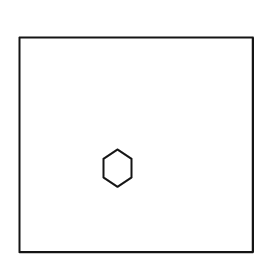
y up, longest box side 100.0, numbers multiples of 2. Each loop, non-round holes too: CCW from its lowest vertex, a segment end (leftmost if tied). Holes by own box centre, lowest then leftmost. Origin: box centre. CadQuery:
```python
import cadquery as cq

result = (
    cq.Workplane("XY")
    .moveTo(-50.0, -46.0)
    .lineTo(50.0, -46.0)
    .lineTo(50.0, 46.0)
    .lineTo(-50.0, 46.0)
    .close()
    .moveTo(-8.0, -18.0)
    .lineTo(-2.0, -14.0)
    .lineTo(-2.0, -6.0)
    .lineTo(-8.0, -2.0)
    .lineTo(-14.0, -6.0)
    .lineTo(-14.0, -14.0)
    .close()
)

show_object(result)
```